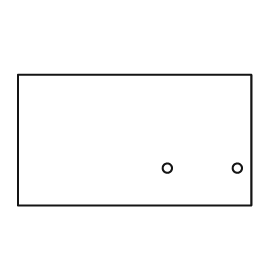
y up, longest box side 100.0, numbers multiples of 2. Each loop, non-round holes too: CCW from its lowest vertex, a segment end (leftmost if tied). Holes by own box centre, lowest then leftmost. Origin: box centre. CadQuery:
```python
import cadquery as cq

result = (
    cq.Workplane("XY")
    .moveTo(-50.0, -28.0)
    .lineTo(50.0, -28.0)
    .lineTo(50.0, 28.0)
    .lineTo(-50.0, 28.0)
    .close()
    .moveTo(14.0, -12.0)
    .circle(2.0)
    .moveTo(44.0, -12.0)
    .circle(2.0)
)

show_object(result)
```